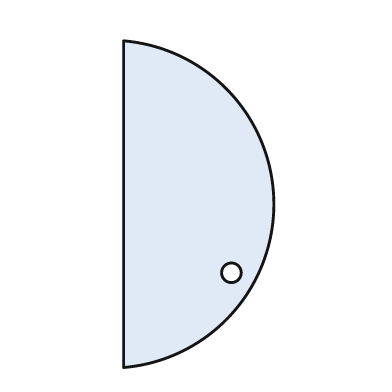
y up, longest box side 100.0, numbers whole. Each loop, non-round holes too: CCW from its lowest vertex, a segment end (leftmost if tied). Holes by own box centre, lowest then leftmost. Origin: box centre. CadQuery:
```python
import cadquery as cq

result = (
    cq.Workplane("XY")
    .moveTo(-23.0, -50.0)
    .threePointArc((23.0, 0.0), (-23.0, 50.0))
    .close()
    .moveTo(10.0, -21.0)
    .circle(3.0)
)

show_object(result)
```